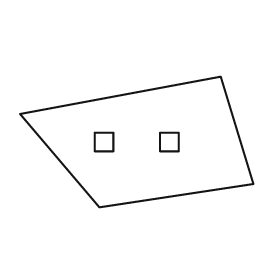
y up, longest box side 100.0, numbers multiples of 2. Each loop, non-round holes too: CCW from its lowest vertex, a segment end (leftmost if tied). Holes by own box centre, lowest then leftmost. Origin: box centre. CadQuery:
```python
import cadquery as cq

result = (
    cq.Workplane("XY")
    .moveTo(-16.0, -28.0)
    .lineTo(50.0, -18.0)
    .lineTo(36.0, 28.0)
    .lineTo(-50.0, 12.0)
    .close()
    .moveTo(-18.0, -4.0)
    .lineTo(-10.0, -4.0)
    .lineTo(-10.0, 4.0)
    .lineTo(-18.0, 4.0)
    .close()
    .moveTo(10.0, -4.0)
    .lineTo(18.0, -4.0)
    .lineTo(18.0, 4.0)
    .lineTo(10.0, 4.0)
    .close()
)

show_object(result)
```